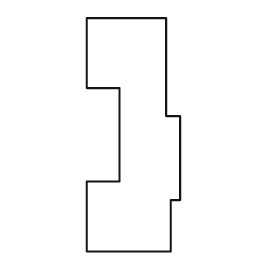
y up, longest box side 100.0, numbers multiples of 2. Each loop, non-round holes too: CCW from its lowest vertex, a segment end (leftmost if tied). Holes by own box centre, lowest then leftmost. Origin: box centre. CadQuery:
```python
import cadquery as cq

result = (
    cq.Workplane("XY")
    .moveTo(-20.0, -50.0)
    .lineTo(16.0, -50.0)
    .lineTo(16.0, -28.0)
    .lineTo(20.0, -28.0)
    .lineTo(20.0, 8.0)
    .lineTo(14.0, 8.0)
    .lineTo(14.0, 50.0)
    .lineTo(-20.0, 50.0)
    .lineTo(-20.0, 20.0)
    .lineTo(-6.0, 20.0)
    .lineTo(-6.0, -20.0)
    .lineTo(-20.0, -20.0)
    .close()
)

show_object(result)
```